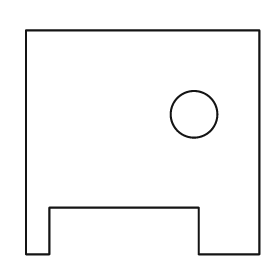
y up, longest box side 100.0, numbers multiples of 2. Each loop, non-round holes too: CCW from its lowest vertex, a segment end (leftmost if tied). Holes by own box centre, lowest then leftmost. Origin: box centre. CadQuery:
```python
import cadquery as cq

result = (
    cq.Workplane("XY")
    .moveTo(-50.0, -48.0)
    .lineTo(-40.0, -48.0)
    .lineTo(-40.0, -28.0)
    .lineTo(24.0, -28.0)
    .lineTo(24.0, -48.0)
    .lineTo(50.0, -48.0)
    .lineTo(50.0, 48.0)
    .lineTo(-50.0, 48.0)
    .close()
    .moveTo(22.0, 12.0)
    .circle(10.0)
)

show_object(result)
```